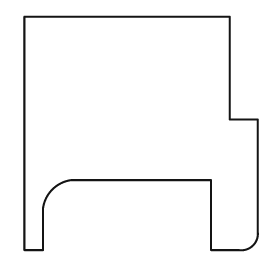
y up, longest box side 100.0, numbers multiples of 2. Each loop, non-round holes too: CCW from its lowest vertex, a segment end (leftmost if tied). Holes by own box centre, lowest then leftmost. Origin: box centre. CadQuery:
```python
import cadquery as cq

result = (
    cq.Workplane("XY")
    .moveTo(-50.0, -50.0)
    .lineTo(-42.0, -50.0)
    .lineTo(-42.0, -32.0)
    .threePointArc((-38.0, -24.0), (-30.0, -20.0))
    .lineTo(30.0, -20.0)
    .lineTo(30.0, -50.0)
    .lineTo(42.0, -50.0)
    .threePointArc((48.0, -48.0), (50.0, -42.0))
    .lineTo(50.0, 6.0)
    .lineTo(38.0, 6.0)
    .lineTo(38.0, 50.0)
    .lineTo(-50.0, 50.0)
    .close()
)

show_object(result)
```